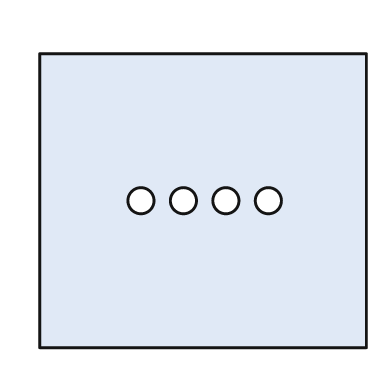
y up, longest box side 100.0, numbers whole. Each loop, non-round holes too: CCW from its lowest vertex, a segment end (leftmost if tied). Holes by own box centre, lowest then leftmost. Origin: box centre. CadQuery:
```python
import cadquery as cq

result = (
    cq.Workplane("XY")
    .moveTo(-50.0, -45.0)
    .lineTo(50.0, -45.0)
    .lineTo(50.0, 45.0)
    .lineTo(-50.0, 45.0)
    .close()
    .moveTo(-19.0, 0.0)
    .circle(4.0)
    .moveTo(-6.0, 0.0)
    .circle(4.0)
    .moveTo(7.0, 0.0)
    .circle(4.0)
    .moveTo(20.0, 0.0)
    .circle(4.0)
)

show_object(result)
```